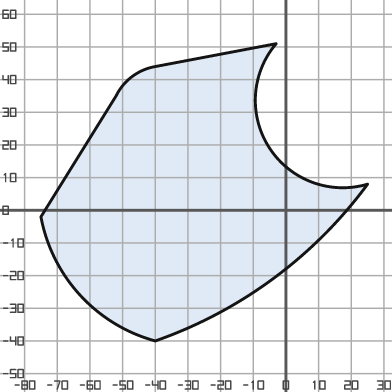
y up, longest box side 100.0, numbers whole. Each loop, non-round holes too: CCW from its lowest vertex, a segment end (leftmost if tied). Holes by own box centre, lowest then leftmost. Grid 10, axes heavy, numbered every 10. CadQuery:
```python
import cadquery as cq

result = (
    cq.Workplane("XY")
    .moveTo(-40.0, -40.0)
    .threePointArc((-4.0, -21.0), (25.0, 8.0))
    .threePointArc((-5.0, 19.0), (-3.0, 51.0))
    .lineTo(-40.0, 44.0)
    .threePointArc((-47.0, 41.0), (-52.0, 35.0))
    .lineTo(-75.0, -2.0)
    .threePointArc((-63.0, -26.0), (-40.0, -40.0))
    .close()
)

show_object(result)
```